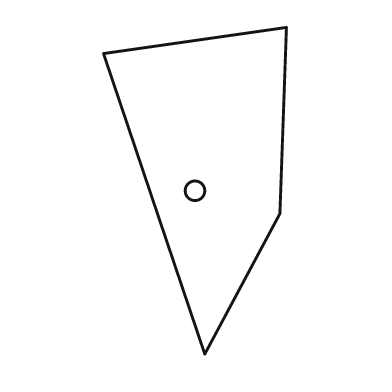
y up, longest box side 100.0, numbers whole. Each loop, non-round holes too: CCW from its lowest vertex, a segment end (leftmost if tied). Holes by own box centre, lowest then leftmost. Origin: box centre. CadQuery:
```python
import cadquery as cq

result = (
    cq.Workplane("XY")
    .moveTo(3.0, -50.0)
    .lineTo(26.0, -7.0)
    .lineTo(28.0, 50.0)
    .lineTo(-28.0, 42.0)
    .close()
    .moveTo(0.0, 0.0)
    .circle(3.0)
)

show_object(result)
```